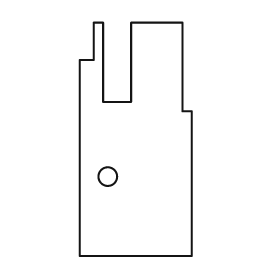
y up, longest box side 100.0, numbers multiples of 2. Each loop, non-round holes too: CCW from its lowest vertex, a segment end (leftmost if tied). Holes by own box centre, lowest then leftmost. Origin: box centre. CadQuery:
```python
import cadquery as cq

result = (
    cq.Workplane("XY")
    .moveTo(-24.0, -50.0)
    .lineTo(24.0, -50.0)
    .lineTo(24.0, 12.0)
    .lineTo(20.0, 12.0)
    .lineTo(20.0, 50.0)
    .lineTo(-2.0, 50.0)
    .lineTo(-2.0, 16.0)
    .lineTo(-14.0, 16.0)
    .lineTo(-14.0, 50.0)
    .lineTo(-18.0, 50.0)
    .lineTo(-18.0, 34.0)
    .lineTo(-24.0, 34.0)
    .close()
    .moveTo(-12.0, -16.0)
    .circle(4.0)
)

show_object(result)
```